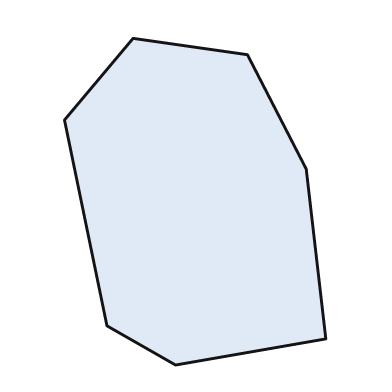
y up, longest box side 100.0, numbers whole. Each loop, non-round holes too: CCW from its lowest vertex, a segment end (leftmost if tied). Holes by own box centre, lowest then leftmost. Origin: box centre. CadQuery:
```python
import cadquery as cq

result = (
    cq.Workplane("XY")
    .moveTo(-6.0, -50.0)
    .lineTo(40.0, -42.0)
    .lineTo(34.0, 10.0)
    .lineTo(16.0, 45.0)
    .lineTo(-19.0, 50.0)
    .lineTo(-40.0, 25.0)
    .lineTo(-27.0, -38.0)
    .close()
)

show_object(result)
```